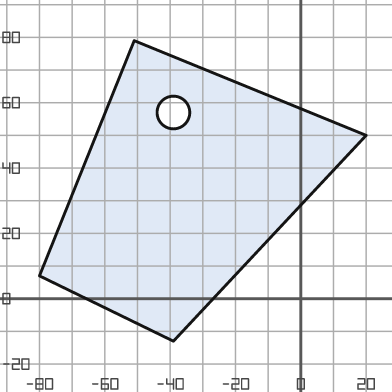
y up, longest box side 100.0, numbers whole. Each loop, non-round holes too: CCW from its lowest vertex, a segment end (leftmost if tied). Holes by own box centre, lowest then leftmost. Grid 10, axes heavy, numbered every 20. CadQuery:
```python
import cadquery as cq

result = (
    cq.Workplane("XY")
    .moveTo(-39.0, -13.0)
    .lineTo(20.0, 50.0)
    .lineTo(-51.0, 79.0)
    .lineTo(-80.0, 7.0)
    .close()
    .moveTo(-39.0, 57.0)
    .circle(5.0)
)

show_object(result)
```